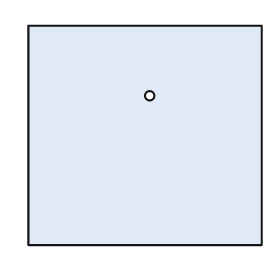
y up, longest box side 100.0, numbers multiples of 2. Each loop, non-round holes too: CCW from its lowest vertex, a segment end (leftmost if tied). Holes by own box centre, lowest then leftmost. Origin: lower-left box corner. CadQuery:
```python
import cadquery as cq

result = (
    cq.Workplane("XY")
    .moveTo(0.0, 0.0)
    .lineTo(100.0, 0.0)
    .lineTo(100.0, 94.0)
    .lineTo(0.0, 94.0)
    .close()
    .moveTo(52.0, 64.0)
    .circle(2.0)
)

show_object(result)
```